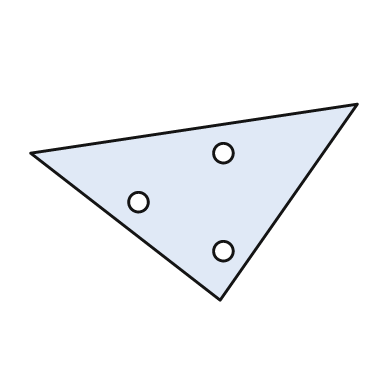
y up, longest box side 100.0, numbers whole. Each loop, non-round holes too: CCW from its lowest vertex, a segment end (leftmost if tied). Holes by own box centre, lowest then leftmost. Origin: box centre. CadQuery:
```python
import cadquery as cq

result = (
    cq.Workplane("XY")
    .moveTo(8.0, -30.0)
    .lineTo(50.0, 30.0)
    .lineTo(-50.0, 15.0)
    .close()
    .moveTo(9.0, -15.0)
    .circle(3.0)
    .moveTo(-17.0, 0.0)
    .circle(3.0)
    .moveTo(9.0, 15.0)
    .circle(3.0)
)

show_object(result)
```